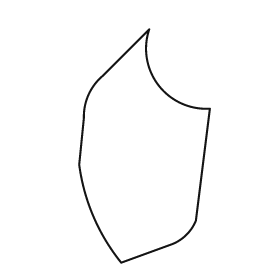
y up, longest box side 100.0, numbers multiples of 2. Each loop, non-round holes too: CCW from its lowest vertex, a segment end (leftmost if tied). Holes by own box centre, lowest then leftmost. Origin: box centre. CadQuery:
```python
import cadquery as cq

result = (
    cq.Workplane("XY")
    .moveTo(-10.0, -50.0)
    .lineTo(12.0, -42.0)
    .threePointArc((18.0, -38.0), (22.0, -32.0))
    .lineTo(28.0, 16.0)
    .threePointArc((6.0, 26.0), (2.0, 50.0))
    .lineTo(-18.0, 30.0)
    .threePointArc((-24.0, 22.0), (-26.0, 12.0))
    .lineTo(-28.0, -8.0)
    .threePointArc((-22.0, -30.0), (-10.0, -50.0))
    .close()
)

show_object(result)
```